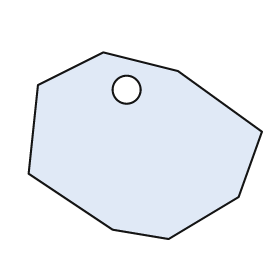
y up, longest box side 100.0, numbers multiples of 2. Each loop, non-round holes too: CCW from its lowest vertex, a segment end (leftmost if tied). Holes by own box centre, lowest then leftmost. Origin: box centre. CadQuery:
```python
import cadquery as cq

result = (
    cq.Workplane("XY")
    .moveTo(10.0, -40.0)
    .lineTo(40.0, -22.0)
    .lineTo(50.0, 6.0)
    .lineTo(14.0, 32.0)
    .lineTo(-18.0, 40.0)
    .lineTo(-46.0, 26.0)
    .lineTo(-50.0, -12.0)
    .lineTo(-14.0, -36.0)
    .close()
    .moveTo(-8.0, 24.0)
    .circle(6.0)
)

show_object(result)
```